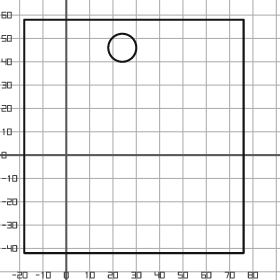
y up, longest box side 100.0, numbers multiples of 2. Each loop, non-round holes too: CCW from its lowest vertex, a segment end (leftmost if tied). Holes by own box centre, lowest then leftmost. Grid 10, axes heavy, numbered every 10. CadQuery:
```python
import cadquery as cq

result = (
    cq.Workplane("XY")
    .moveTo(-18.0, -42.0)
    .lineTo(76.0, -42.0)
    .lineTo(76.0, 58.0)
    .lineTo(-18.0, 58.0)
    .close()
    .moveTo(24.0, 46.0)
    .circle(6.0)
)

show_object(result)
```